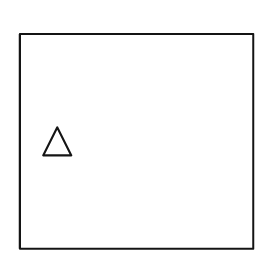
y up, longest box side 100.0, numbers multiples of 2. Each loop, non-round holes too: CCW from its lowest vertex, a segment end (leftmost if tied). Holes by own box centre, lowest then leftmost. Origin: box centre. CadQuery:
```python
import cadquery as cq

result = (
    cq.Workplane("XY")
    .moveTo(-50.0, -46.0)
    .lineTo(50.0, -46.0)
    .lineTo(50.0, 46.0)
    .lineTo(-50.0, 46.0)
    .close()
    .moveTo(-40.0, -6.0)
    .lineTo(-28.0, -6.0)
    .lineTo(-34.0, 6.0)
    .close()
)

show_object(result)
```